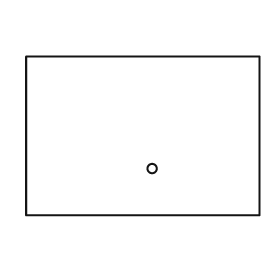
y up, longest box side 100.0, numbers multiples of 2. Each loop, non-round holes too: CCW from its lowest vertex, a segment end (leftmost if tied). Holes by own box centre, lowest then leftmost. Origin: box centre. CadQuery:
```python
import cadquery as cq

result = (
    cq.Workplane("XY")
    .moveTo(-50.0, -34.0)
    .lineTo(50.0, -34.0)
    .lineTo(50.0, 34.0)
    .lineTo(-50.0, 34.0)
    .close()
    .moveTo(4.0, -14.0)
    .circle(2.0)
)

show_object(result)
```